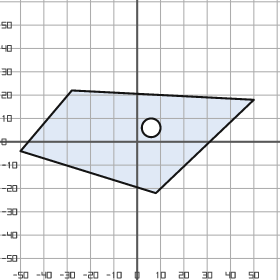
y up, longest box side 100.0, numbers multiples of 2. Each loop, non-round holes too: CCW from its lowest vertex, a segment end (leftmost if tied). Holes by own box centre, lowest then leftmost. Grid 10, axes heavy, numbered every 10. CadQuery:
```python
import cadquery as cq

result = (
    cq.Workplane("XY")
    .moveTo(8.0, -22.0)
    .lineTo(50.0, 18.0)
    .lineTo(-28.0, 22.0)
    .lineTo(-50.0, -4.0)
    .close()
    .moveTo(6.0, 6.0)
    .circle(4.0)
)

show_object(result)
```